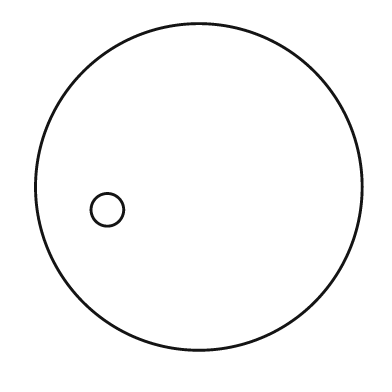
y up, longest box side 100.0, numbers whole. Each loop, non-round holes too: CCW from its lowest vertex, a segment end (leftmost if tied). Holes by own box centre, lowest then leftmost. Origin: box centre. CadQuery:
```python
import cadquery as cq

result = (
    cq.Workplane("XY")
    .moveTo(0.0, 0.0)
    .circle(50.0)
    .moveTo(-28.0, -7.0)
    .circle(5.0)
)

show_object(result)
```